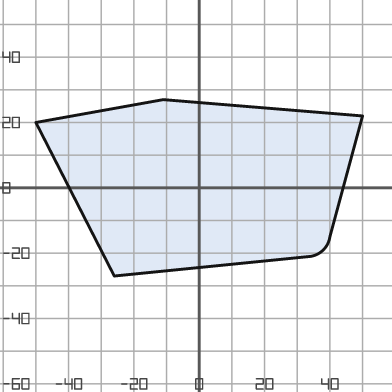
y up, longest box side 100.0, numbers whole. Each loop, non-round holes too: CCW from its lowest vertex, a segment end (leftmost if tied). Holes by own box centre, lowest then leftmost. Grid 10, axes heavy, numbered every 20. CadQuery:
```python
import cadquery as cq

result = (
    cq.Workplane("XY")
    .moveTo(-26.0, -27.0)
    .lineTo(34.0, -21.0)
    .threePointArc((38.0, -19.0), (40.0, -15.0))
    .lineTo(50.0, 22.0)
    .lineTo(-11.0, 27.0)
    .lineTo(-50.0, 20.0)
    .close()
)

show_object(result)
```